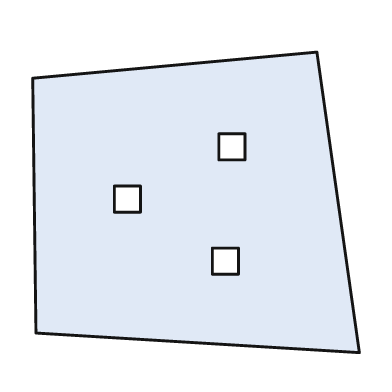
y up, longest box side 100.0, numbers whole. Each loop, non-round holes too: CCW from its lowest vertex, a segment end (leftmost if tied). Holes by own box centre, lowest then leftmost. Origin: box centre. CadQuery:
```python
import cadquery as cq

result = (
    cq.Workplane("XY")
    .moveTo(50.0, -46.0)
    .lineTo(37.0, 46.0)
    .lineTo(-50.0, 38.0)
    .lineTo(-49.0, -40.0)
    .close()
    .moveTo(5.0, -22.0)
    .lineTo(13.0, -22.0)
    .lineTo(13.0, -14.0)
    .lineTo(5.0, -14.0)
    .close()
    .moveTo(-25.0, -3.0)
    .lineTo(-17.0, -3.0)
    .lineTo(-17.0, 5.0)
    .lineTo(-25.0, 5.0)
    .close()
    .moveTo(7.0, 13.0)
    .lineTo(15.0, 13.0)
    .lineTo(15.0, 21.0)
    .lineTo(7.0, 21.0)
    .close()
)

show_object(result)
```